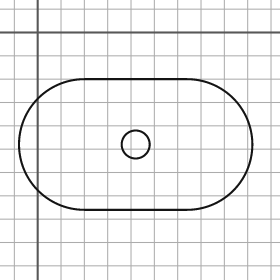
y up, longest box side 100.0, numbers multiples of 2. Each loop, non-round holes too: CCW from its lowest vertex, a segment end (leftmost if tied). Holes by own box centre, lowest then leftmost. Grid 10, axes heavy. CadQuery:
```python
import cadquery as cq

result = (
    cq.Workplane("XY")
    .moveTo(20.0, -76.0)
    .lineTo(64.0, -76.0)
    .threePointArc((92.0, -48.0), (64.0, -20.0))
    .lineTo(20.0, -20.0)
    .threePointArc((-8.0, -48.0), (20.0, -76.0))
    .close()
    .moveTo(42.0, -48.0)
    .circle(6.0)
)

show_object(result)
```